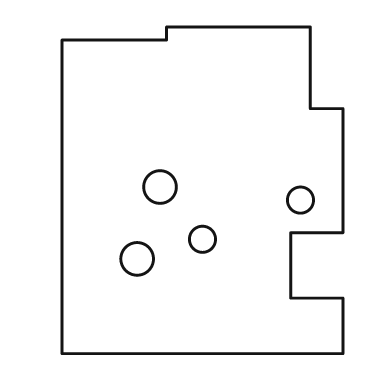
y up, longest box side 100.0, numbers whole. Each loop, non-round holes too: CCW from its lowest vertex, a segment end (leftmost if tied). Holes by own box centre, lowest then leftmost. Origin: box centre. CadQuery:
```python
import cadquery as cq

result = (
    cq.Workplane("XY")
    .moveTo(-43.0, -50.0)
    .lineTo(43.0, -50.0)
    .lineTo(43.0, -33.0)
    .lineTo(27.0, -33.0)
    .lineTo(27.0, -13.0)
    .lineTo(43.0, -13.0)
    .lineTo(43.0, 25.0)
    .lineTo(33.0, 25.0)
    .lineTo(33.0, 50.0)
    .lineTo(-11.0, 50.0)
    .lineTo(-11.0, 46.0)
    .lineTo(-43.0, 46.0)
    .close()
    .moveTo(-20.0, -21.0)
    .circle(5.0)
    .moveTo(0.0, -15.0)
    .circle(4.0)
    .moveTo(30.0, -3.0)
    .circle(4.0)
    .moveTo(-13.0, 1.0)
    .circle(5.0)
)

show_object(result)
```